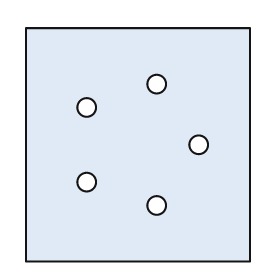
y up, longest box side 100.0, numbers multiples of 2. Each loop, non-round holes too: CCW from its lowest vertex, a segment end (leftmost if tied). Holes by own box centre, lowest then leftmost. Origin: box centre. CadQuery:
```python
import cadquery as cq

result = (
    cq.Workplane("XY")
    .moveTo(-48.0, -50.0)
    .lineTo(48.0, -50.0)
    .lineTo(48.0, 50.0)
    .lineTo(-48.0, 50.0)
    .close()
    .moveTo(8.0, -26.0)
    .circle(4.0)
    .moveTo(-22.0, -16.0)
    .circle(4.0)
    .moveTo(26.0, 0.0)
    .circle(4.0)
    .moveTo(-22.0, 16.0)
    .circle(4.0)
    .moveTo(8.0, 26.0)
    .circle(4.0)
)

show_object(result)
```